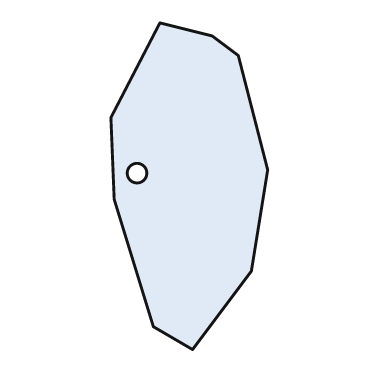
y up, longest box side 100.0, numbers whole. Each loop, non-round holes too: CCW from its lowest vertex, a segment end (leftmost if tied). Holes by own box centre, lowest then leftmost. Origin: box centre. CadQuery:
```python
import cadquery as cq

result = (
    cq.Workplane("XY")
    .moveTo(1.0, -50.0)
    .lineTo(19.0, -26.0)
    .lineTo(24.0, 5.0)
    .lineTo(15.0, 40.0)
    .lineTo(7.0, 46.0)
    .lineTo(-9.0, 50.0)
    .lineTo(-24.0, 21.0)
    .lineTo(-23.0, -4.0)
    .lineTo(-11.0, -43.0)
    .close()
    .moveTo(-16.0, 4.0)
    .circle(3.0)
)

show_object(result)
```